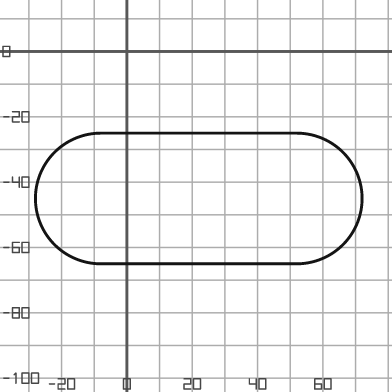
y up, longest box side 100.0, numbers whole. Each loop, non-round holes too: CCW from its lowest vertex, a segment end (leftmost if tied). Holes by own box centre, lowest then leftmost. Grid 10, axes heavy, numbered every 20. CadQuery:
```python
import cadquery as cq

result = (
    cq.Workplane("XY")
    .moveTo(-8.0, -65.0)
    .lineTo(52.0, -65.0)
    .threePointArc((72.0, -45.0), (52.0, -25.0))
    .lineTo(-8.0, -25.0)
    .threePointArc((-28.0, -45.0), (-8.0, -65.0))
    .close()
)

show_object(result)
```